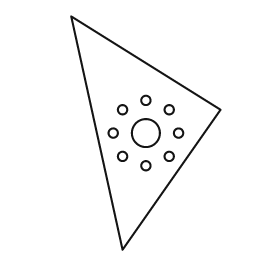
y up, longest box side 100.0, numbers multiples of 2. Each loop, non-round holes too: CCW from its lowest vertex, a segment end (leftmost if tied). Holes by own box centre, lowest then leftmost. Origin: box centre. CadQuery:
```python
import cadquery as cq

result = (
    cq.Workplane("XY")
    .moveTo(-10.0, -50.0)
    .lineTo(32.0, 10.0)
    .lineTo(-32.0, 50.0)
    .close()
    .moveTo(0.0, -14.0)
    .circle(2.0)
    .moveTo(-10.0, -10.0)
    .circle(2.0)
    .moveTo(10.0, -10.0)
    .circle(2.0)
    .moveTo(-14.0, 0.0)
    .circle(2.0)
    .moveTo(0.0, 0.0)
    .circle(6.0)
    .moveTo(14.0, 0.0)
    .circle(2.0)
    .moveTo(-10.0, 10.0)
    .circle(2.0)
    .moveTo(10.0, 10.0)
    .circle(2.0)
    .moveTo(0.0, 14.0)
    .circle(2.0)
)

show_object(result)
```